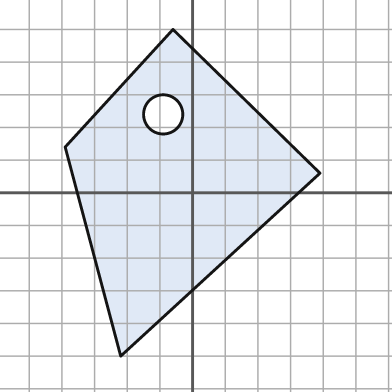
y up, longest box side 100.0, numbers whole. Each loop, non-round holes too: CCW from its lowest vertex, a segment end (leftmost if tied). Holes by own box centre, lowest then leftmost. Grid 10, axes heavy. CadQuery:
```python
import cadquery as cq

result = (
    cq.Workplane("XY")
    .moveTo(-22.0, -50.0)
    .lineTo(39.0, 6.0)
    .lineTo(-6.0, 50.0)
    .lineTo(-39.0, 14.0)
    .close()
    .moveTo(-9.0, 24.0)
    .circle(6.0)
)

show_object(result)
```